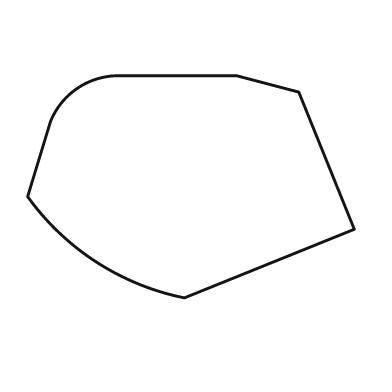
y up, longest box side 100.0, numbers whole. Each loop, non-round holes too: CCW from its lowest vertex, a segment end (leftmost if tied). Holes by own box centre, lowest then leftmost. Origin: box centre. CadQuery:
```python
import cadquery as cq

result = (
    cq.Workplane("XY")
    .moveTo(-2.0, -34.0)
    .lineTo(50.0, -13.0)
    .lineTo(33.0, 29.0)
    .lineTo(14.0, 34.0)
    .lineTo(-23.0, 34.0)
    .threePointArc((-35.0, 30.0), (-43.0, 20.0))
    .lineTo(-50.0, -3.0)
    .threePointArc((-29.0, -23.0), (-2.0, -34.0))
    .close()
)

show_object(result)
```